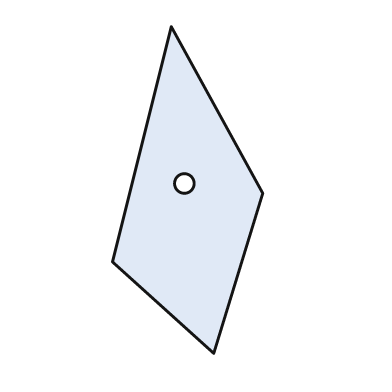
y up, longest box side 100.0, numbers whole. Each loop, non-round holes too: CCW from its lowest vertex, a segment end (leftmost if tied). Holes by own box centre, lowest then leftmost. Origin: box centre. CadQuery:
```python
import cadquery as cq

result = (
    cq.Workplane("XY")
    .moveTo(8.0, -50.0)
    .lineTo(23.0, -1.0)
    .lineTo(-5.0, 50.0)
    .lineTo(-23.0, -22.0)
    .close()
    .moveTo(-1.0, 2.0)
    .circle(3.0)
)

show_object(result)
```